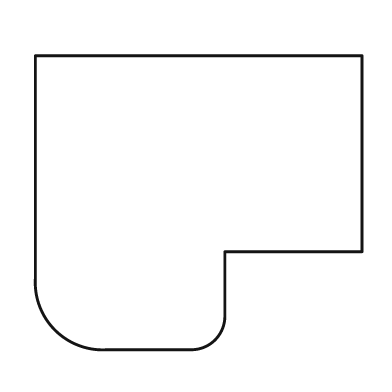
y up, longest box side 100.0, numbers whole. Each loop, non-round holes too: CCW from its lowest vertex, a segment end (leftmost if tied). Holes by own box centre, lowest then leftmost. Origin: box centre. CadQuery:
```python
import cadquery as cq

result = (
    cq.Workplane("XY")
    .moveTo(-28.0, -45.0)
    .lineTo(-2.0, -45.0)
    .threePointArc((5.0, -42.0), (8.0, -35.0))
    .lineTo(8.0, -15.0)
    .lineTo(50.0, -15.0)
    .lineTo(50.0, 45.0)
    .lineTo(-50.0, 45.0)
    .lineTo(-50.0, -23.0)
    .threePointArc((-44.0, -39.0), (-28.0, -45.0))
    .close()
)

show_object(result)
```